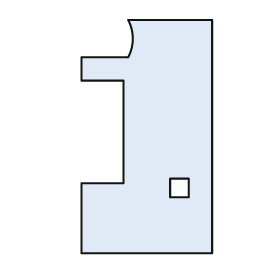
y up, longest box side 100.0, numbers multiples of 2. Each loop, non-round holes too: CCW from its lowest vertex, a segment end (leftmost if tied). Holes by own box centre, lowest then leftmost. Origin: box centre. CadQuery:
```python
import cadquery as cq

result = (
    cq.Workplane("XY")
    .moveTo(-28.0, -50.0)
    .lineTo(28.0, -50.0)
    .lineTo(28.0, 50.0)
    .lineTo(-8.0, 50.0)
    .threePointArc((-6.0, 42.0), (-8.0, 34.0))
    .lineTo(-28.0, 34.0)
    .lineTo(-28.0, 24.0)
    .lineTo(-10.0, 24.0)
    .lineTo(-10.0, -20.0)
    .lineTo(-28.0, -20.0)
    .close()
    .moveTo(10.0, -26.0)
    .lineTo(18.0, -26.0)
    .lineTo(18.0, -18.0)
    .lineTo(10.0, -18.0)
    .close()
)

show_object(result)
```